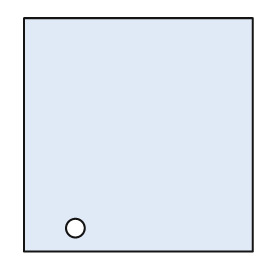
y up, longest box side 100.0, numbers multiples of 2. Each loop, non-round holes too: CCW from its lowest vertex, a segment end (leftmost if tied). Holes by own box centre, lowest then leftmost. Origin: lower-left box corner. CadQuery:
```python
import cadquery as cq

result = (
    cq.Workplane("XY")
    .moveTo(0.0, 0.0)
    .lineTo(98.0, 0.0)
    .lineTo(98.0, 100.0)
    .lineTo(0.0, 100.0)
    .close()
    .moveTo(22.0, 10.0)
    .circle(4.0)
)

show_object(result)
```